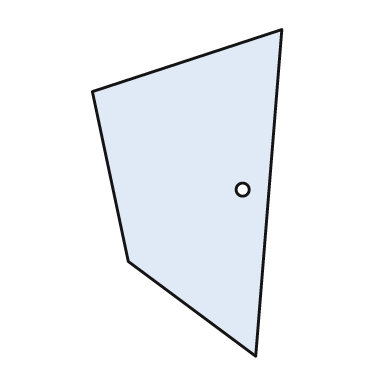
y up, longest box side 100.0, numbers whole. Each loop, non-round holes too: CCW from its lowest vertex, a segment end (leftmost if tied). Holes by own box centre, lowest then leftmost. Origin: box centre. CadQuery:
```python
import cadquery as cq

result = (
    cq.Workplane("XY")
    .moveTo(21.0, -50.0)
    .lineTo(29.0, 50.0)
    .lineTo(-29.0, 31.0)
    .lineTo(-18.0, -21.0)
    .close()
    .moveTo(17.0, 1.0)
    .circle(2.0)
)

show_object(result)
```